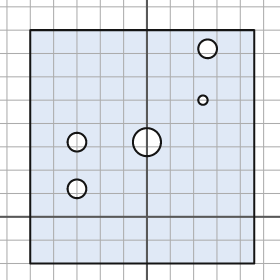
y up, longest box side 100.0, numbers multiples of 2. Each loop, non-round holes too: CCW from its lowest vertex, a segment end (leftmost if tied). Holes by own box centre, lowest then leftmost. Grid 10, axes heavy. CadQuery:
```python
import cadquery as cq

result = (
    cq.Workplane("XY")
    .moveTo(-50.0, -20.0)
    .lineTo(46.0, -20.0)
    .lineTo(46.0, 80.0)
    .lineTo(-50.0, 80.0)
    .close()
    .moveTo(-30.0, 12.0)
    .circle(4.0)
    .moveTo(-30.0, 32.0)
    .circle(4.0)
    .moveTo(0.0, 32.0)
    .circle(6.0)
    .moveTo(24.0, 50.0)
    .circle(2.0)
    .moveTo(26.0, 72.0)
    .circle(4.0)
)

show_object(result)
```